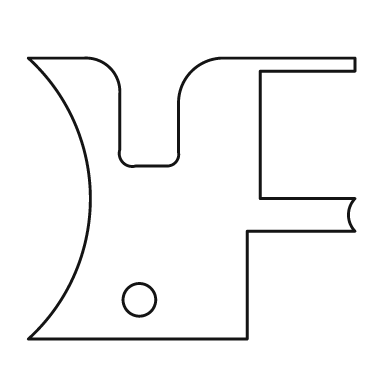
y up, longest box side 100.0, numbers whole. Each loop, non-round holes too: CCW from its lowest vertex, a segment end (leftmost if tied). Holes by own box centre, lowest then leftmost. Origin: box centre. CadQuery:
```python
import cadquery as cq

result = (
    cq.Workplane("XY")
    .moveTo(-50.0, -43.0)
    .lineTo(17.0, -43.0)
    .lineTo(17.0, -10.0)
    .lineTo(50.0, -10.0)
    .threePointArc((48.0, -5.0), (50.0, 0.0))
    .lineTo(21.0, 0.0)
    .lineTo(21.0, 39.0)
    .lineTo(50.0, 39.0)
    .lineTo(50.0, 43.0)
    .lineTo(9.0, 43.0)
    .threePointArc((0.0, 39.0), (-4.0, 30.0))
    .lineTo(-4.0, 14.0)
    .threePointArc((-5.0, 11.0), (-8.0, 10.0))
    .lineTo(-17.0, 10.0)
    .threePointArc((-21.0, 11.0), (-22.0, 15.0))
    .lineTo(-22.0, 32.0)
    .threePointArc((-25.0, 40.0), (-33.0, 43.0))
    .lineTo(-50.0, 43.0)
    .threePointArc((-31.0, 0.0), (-50.0, -43.0))
    .close()
    .moveTo(-16.0, -31.0)
    .circle(5.0)
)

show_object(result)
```